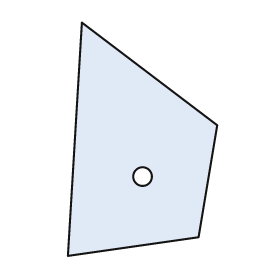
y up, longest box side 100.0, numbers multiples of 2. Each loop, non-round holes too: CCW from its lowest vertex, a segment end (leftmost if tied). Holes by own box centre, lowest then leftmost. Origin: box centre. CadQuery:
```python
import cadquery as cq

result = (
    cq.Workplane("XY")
    .moveTo(-32.0, -50.0)
    .lineTo(24.0, -42.0)
    .lineTo(32.0, 6.0)
    .lineTo(-26.0, 50.0)
    .close()
    .moveTo(0.0, -16.0)
    .circle(4.0)
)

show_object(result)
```